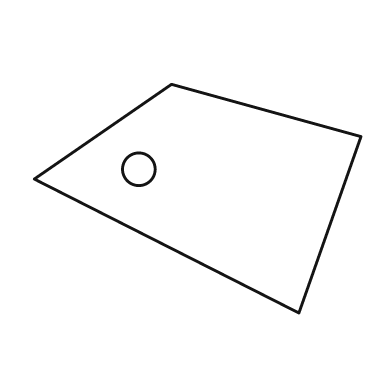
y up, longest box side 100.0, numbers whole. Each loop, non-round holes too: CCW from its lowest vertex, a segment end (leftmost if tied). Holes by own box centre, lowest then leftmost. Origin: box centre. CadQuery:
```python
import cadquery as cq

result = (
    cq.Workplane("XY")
    .moveTo(31.0, -35.0)
    .lineTo(50.0, 19.0)
    .lineTo(-8.0, 35.0)
    .lineTo(-50.0, 6.0)
    .close()
    .moveTo(-18.0, 9.0)
    .circle(5.0)
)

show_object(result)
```